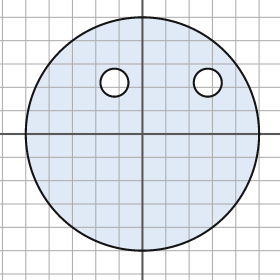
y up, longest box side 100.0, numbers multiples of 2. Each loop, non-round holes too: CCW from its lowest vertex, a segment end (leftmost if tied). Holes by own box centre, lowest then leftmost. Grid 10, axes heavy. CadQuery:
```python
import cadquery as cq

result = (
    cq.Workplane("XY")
    .moveTo(0.0, 0.0)
    .circle(50.0)
    .moveTo(-12.0, 22.0)
    .circle(6.0)
    .moveTo(28.0, 22.0)
    .circle(6.0)
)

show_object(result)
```